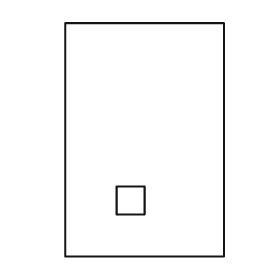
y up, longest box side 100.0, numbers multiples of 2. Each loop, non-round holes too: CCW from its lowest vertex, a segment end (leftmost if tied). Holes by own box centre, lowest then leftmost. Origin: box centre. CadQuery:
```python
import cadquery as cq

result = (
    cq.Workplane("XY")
    .moveTo(-34.0, -50.0)
    .lineTo(34.0, -50.0)
    .lineTo(34.0, 50.0)
    .lineTo(-34.0, 50.0)
    .close()
    .moveTo(-12.0, -32.0)
    .lineTo(0.0, -32.0)
    .lineTo(0.0, -20.0)
    .lineTo(-12.0, -20.0)
    .close()
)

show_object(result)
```